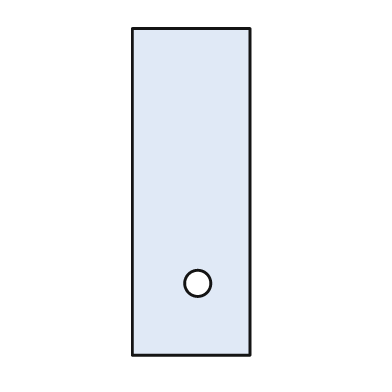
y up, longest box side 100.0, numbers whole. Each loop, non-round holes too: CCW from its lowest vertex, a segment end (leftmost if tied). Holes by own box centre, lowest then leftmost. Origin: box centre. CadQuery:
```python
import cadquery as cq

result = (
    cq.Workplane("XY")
    .moveTo(-18.0, -50.0)
    .lineTo(18.0, -50.0)
    .lineTo(18.0, 50.0)
    .lineTo(-18.0, 50.0)
    .close()
    .moveTo(2.0, -28.0)
    .circle(4.0)
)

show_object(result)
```